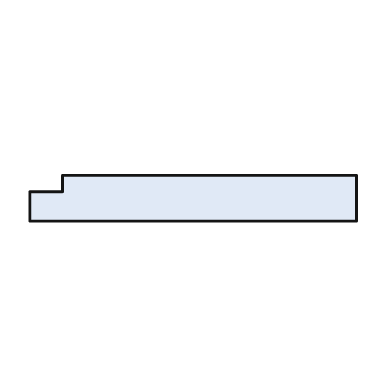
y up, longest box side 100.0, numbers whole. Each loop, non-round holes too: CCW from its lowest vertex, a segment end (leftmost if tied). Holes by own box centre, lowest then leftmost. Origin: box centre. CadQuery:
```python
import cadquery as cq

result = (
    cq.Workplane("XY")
    .moveTo(-50.0, -7.0)
    .lineTo(50.0, -7.0)
    .lineTo(50.0, 7.0)
    .lineTo(-40.0, 7.0)
    .lineTo(-40.0, 2.0)
    .lineTo(-50.0, 2.0)
    .close()
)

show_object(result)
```